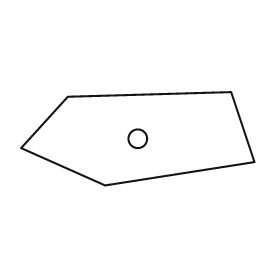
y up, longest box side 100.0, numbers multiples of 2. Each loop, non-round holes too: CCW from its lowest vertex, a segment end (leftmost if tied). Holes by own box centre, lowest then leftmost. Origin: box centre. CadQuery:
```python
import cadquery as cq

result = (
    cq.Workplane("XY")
    .moveTo(-14.0, -20.0)
    .lineTo(50.0, -10.0)
    .lineTo(40.0, 20.0)
    .lineTo(-30.0, 18.0)
    .lineTo(-50.0, -4.0)
    .close()
    .moveTo(0.0, 0.0)
    .circle(4.0)
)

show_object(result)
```